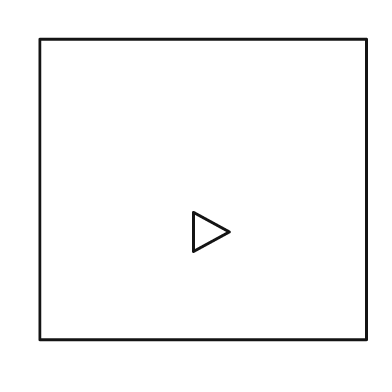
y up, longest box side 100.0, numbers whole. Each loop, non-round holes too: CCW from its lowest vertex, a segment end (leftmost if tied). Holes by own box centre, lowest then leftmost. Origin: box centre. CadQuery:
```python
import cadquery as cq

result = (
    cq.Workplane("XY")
    .moveTo(-50.0, -46.0)
    .lineTo(50.0, -46.0)
    .lineTo(50.0, 46.0)
    .lineTo(-50.0, 46.0)
    .close()
    .moveTo(-3.0, -19.0)
    .lineTo(8.0, -13.0)
    .lineTo(-3.0, -7.0)
    .close()
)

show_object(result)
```